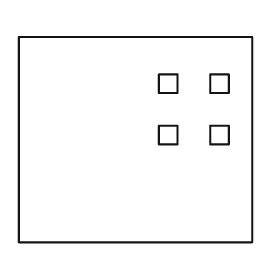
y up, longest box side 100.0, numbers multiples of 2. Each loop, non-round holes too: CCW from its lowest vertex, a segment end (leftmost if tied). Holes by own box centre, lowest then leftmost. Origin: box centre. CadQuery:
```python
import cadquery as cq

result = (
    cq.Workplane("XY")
    .moveTo(-50.0, -44.0)
    .lineTo(50.0, -44.0)
    .lineTo(50.0, 44.0)
    .lineTo(-50.0, 44.0)
    .close()
    .moveTo(10.0, -2.0)
    .lineTo(18.0, -2.0)
    .lineTo(18.0, 6.0)
    .lineTo(10.0, 6.0)
    .close()
    .moveTo(32.0, -2.0)
    .lineTo(40.0, -2.0)
    .lineTo(40.0, 6.0)
    .lineTo(32.0, 6.0)
    .close()
    .moveTo(10.0, 20.0)
    .lineTo(18.0, 20.0)
    .lineTo(18.0, 28.0)
    .lineTo(10.0, 28.0)
    .close()
    .moveTo(32.0, 20.0)
    .lineTo(40.0, 20.0)
    .lineTo(40.0, 28.0)
    .lineTo(32.0, 28.0)
    .close()
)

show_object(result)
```